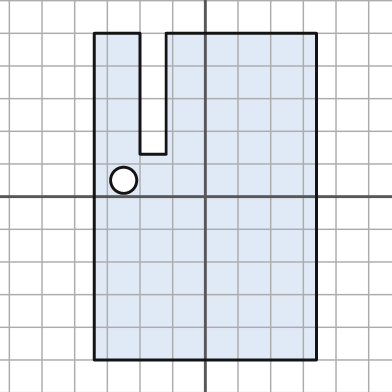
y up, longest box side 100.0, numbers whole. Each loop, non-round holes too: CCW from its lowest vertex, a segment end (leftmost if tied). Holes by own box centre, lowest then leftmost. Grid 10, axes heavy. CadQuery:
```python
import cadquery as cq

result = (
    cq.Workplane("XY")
    .moveTo(-34.0, -50.0)
    .lineTo(34.0, -50.0)
    .lineTo(34.0, 50.0)
    .lineTo(-12.0, 50.0)
    .lineTo(-12.0, 13.0)
    .lineTo(-20.0, 13.0)
    .lineTo(-20.0, 50.0)
    .lineTo(-34.0, 50.0)
    .close()
    .moveTo(-25.0, 5.0)
    .circle(4.0)
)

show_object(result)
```